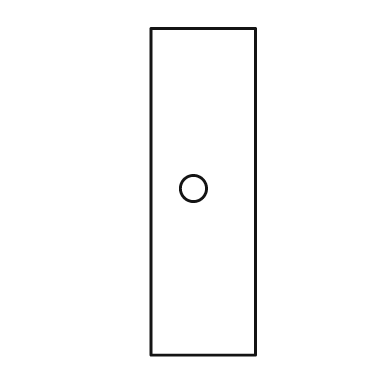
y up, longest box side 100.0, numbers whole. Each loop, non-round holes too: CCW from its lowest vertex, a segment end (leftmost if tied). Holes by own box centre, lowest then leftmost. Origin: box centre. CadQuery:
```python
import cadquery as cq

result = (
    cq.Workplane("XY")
    .moveTo(-16.0, -50.0)
    .lineTo(16.0, -50.0)
    .lineTo(16.0, 50.0)
    .lineTo(-16.0, 50.0)
    .close()
    .moveTo(-3.0, 1.0)
    .circle(4.0)
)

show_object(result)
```